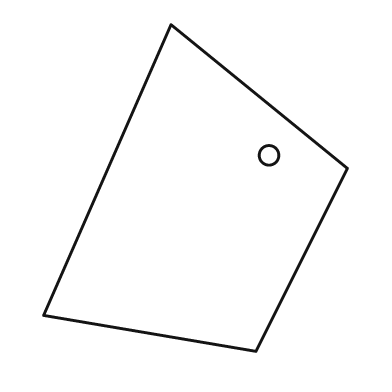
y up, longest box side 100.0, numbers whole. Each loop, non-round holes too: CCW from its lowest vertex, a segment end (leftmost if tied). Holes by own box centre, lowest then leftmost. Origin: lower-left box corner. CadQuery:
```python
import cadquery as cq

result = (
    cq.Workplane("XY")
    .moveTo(65.0, 0.0)
    .lineTo(93.0, 56.0)
    .lineTo(39.0, 100.0)
    .lineTo(0.0, 11.0)
    .close()
    .moveTo(69.0, 60.0)
    .circle(3.0)
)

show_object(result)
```